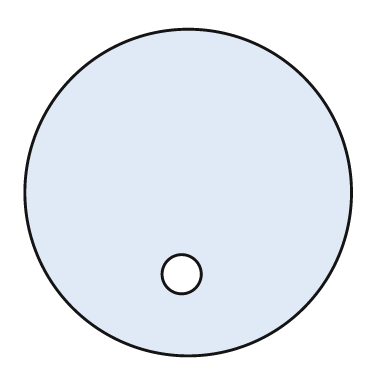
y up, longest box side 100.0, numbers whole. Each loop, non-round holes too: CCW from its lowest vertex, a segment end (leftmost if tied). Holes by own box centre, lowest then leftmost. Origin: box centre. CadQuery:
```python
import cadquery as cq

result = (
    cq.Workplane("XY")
    .moveTo(0.0, 0.0)
    .circle(50.0)
    .moveTo(-2.0, -25.0)
    .circle(6.0)
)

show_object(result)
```